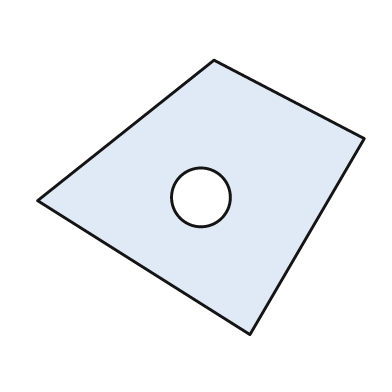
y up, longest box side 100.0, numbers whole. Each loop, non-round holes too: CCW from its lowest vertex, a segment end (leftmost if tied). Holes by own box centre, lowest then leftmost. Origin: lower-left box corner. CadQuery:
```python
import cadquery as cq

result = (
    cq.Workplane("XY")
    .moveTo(65.0, 0.0)
    .lineTo(100.0, 60.0)
    .lineTo(54.0, 84.0)
    .lineTo(0.0, 41.0)
    .close()
    .moveTo(50.0, 42.0)
    .circle(9.0)
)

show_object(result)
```